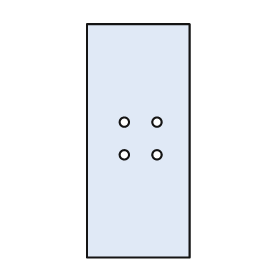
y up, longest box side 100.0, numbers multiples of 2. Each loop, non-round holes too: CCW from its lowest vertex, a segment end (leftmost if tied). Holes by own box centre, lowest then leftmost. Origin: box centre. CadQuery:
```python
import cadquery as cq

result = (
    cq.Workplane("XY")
    .moveTo(-22.0, -50.0)
    .lineTo(22.0, -50.0)
    .lineTo(22.0, 50.0)
    .lineTo(-22.0, 50.0)
    .close()
    .moveTo(-6.0, -6.0)
    .circle(2.0)
    .moveTo(8.0, -6.0)
    .circle(2.0)
    .moveTo(-6.0, 8.0)
    .circle(2.0)
    .moveTo(8.0, 8.0)
    .circle(2.0)
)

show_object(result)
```